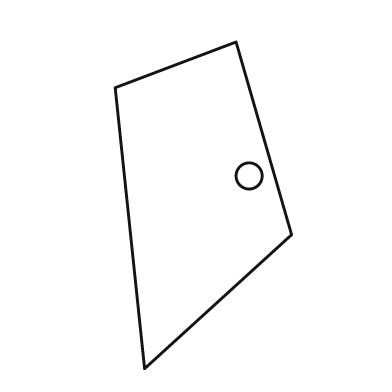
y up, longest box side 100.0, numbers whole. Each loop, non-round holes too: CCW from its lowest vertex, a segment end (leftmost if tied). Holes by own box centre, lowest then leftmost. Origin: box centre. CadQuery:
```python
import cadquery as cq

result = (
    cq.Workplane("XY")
    .moveTo(-18.0, -50.0)
    .lineTo(27.0, -9.0)
    .lineTo(10.0, 50.0)
    .lineTo(-27.0, 36.0)
    .close()
    .moveTo(14.0, 9.0)
    .circle(4.0)
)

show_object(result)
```